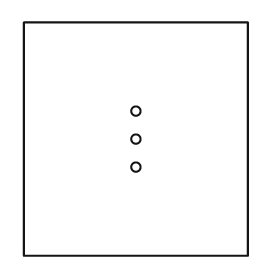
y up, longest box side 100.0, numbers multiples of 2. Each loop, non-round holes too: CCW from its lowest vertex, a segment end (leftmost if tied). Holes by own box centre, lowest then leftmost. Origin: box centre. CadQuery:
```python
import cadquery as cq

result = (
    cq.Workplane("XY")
    .moveTo(-48.0, -50.0)
    .lineTo(48.0, -50.0)
    .lineTo(48.0, 50.0)
    .lineTo(-48.0, 50.0)
    .close()
    .moveTo(0.0, -12.0)
    .circle(2.0)
    .moveTo(0.0, 0.0)
    .circle(2.0)
    .moveTo(0.0, 12.0)
    .circle(2.0)
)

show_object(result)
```